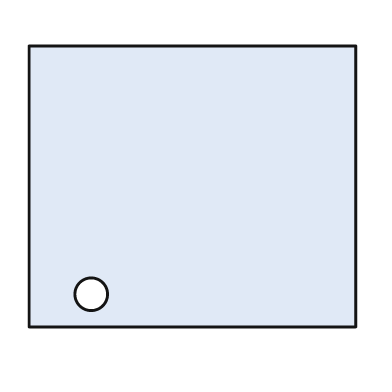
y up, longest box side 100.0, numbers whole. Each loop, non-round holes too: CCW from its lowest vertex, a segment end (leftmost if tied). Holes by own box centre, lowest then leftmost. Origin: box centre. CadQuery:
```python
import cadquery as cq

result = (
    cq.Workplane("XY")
    .moveTo(-50.0, -43.0)
    .lineTo(50.0, -43.0)
    .lineTo(50.0, 43.0)
    .lineTo(-50.0, 43.0)
    .close()
    .moveTo(-31.0, -33.0)
    .circle(5.0)
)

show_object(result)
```